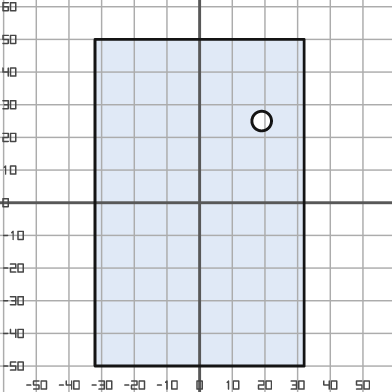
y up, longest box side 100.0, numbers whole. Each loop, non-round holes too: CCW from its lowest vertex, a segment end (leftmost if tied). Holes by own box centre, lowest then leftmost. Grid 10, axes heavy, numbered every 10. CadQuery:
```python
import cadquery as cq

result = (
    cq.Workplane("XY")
    .moveTo(-32.0, -50.0)
    .lineTo(32.0, -50.0)
    .lineTo(32.0, 50.0)
    .lineTo(-32.0, 50.0)
    .close()
    .moveTo(19.0, 25.0)
    .circle(3.0)
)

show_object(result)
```